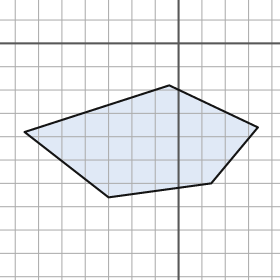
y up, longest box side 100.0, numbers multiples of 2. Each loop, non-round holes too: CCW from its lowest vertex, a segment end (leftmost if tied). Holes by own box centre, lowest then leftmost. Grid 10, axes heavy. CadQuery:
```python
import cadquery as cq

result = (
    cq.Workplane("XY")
    .moveTo(-30.0, -66.0)
    .lineTo(14.0, -60.0)
    .lineTo(34.0, -36.0)
    .lineTo(-4.0, -18.0)
    .lineTo(-66.0, -38.0)
    .close()
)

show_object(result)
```